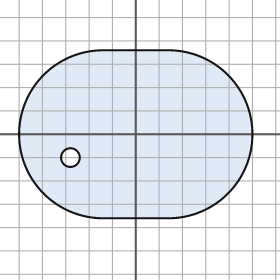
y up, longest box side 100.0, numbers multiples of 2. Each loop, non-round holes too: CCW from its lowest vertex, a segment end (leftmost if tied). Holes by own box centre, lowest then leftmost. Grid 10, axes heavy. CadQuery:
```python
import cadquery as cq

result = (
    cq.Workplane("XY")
    .moveTo(-14.0, -36.0)
    .lineTo(14.0, -36.0)
    .threePointArc((50.0, 0.0), (14.0, 36.0))
    .lineTo(-14.0, 36.0)
    .threePointArc((-50.0, 0.0), (-14.0, -36.0))
    .close()
    .moveTo(-28.0, -10.0)
    .circle(4.0)
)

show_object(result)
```